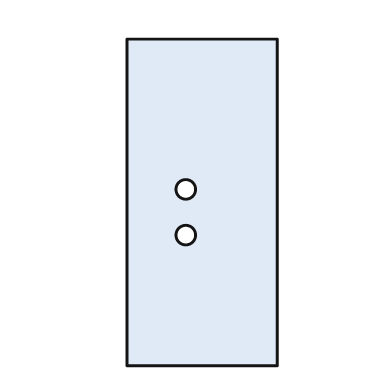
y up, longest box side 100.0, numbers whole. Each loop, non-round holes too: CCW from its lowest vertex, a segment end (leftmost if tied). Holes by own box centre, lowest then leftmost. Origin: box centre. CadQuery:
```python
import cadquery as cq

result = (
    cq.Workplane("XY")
    .moveTo(-23.0, -50.0)
    .lineTo(23.0, -50.0)
    .lineTo(23.0, 50.0)
    .lineTo(-23.0, 50.0)
    .close()
    .moveTo(-5.0, -10.0)
    .circle(3.0)
    .moveTo(-5.0, 4.0)
    .circle(3.0)
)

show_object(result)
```